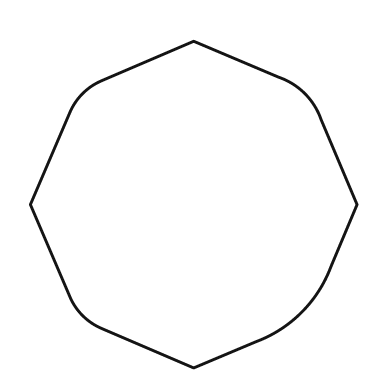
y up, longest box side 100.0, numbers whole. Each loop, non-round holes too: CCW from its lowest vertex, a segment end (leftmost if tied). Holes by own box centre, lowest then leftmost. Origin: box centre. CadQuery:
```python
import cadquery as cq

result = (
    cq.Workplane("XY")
    .moveTo(0.0, -50.0)
    .lineTo(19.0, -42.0)
    .threePointArc((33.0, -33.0), (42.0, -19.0))
    .lineTo(50.0, 0.0)
    .lineTo(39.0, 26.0)
    .threePointArc((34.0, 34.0), (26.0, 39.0))
    .lineTo(0.0, 50.0)
    .lineTo(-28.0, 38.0)
    .threePointArc((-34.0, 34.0), (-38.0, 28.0))
    .lineTo(-50.0, 0.0)
    .lineTo(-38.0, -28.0)
    .threePointArc((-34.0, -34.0), (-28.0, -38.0))
    .close()
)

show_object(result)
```